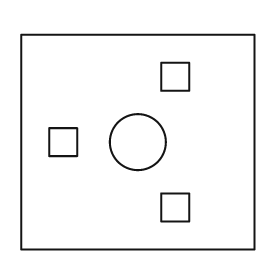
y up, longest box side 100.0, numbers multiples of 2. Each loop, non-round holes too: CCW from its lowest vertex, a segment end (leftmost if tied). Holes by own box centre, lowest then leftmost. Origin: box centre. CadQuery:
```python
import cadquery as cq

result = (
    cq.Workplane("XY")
    .moveTo(-50.0, -46.0)
    .lineTo(50.0, -46.0)
    .lineTo(50.0, 46.0)
    .lineTo(-50.0, 46.0)
    .close()
    .moveTo(10.0, -34.0)
    .lineTo(22.0, -34.0)
    .lineTo(22.0, -22.0)
    .lineTo(10.0, -22.0)
    .close()
    .moveTo(-38.0, -6.0)
    .lineTo(-26.0, -6.0)
    .lineTo(-26.0, 6.0)
    .lineTo(-38.0, 6.0)
    .close()
    .moveTo(0.0, 0.0)
    .circle(12.0)
    .moveTo(10.0, 22.0)
    .lineTo(22.0, 22.0)
    .lineTo(22.0, 34.0)
    .lineTo(10.0, 34.0)
    .close()
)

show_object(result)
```